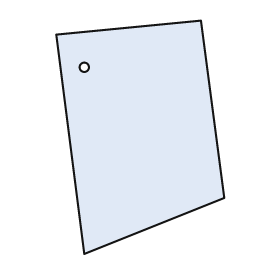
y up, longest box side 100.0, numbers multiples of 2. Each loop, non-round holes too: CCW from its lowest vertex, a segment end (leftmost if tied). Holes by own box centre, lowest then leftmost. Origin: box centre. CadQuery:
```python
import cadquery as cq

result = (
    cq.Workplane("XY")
    .moveTo(-24.0, -50.0)
    .lineTo(36.0, -26.0)
    .lineTo(26.0, 50.0)
    .lineTo(-36.0, 44.0)
    .close()
    .moveTo(-24.0, 30.0)
    .circle(2.0)
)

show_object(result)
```